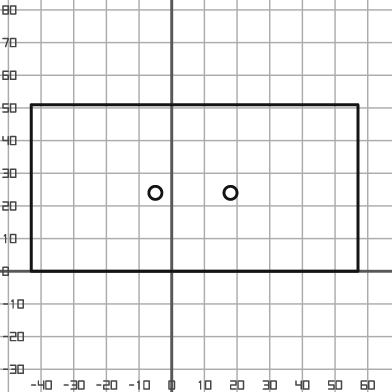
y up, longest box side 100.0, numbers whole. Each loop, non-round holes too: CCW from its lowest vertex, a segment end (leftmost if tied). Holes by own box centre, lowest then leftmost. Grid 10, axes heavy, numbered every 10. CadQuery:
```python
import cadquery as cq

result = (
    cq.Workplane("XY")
    .moveTo(-43.0, 0.0)
    .lineTo(57.0, 0.0)
    .lineTo(57.0, 51.0)
    .lineTo(-43.0, 51.0)
    .close()
    .moveTo(-5.0, 24.0)
    .circle(2.0)
    .moveTo(18.0, 24.0)
    .circle(2.0)
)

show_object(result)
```